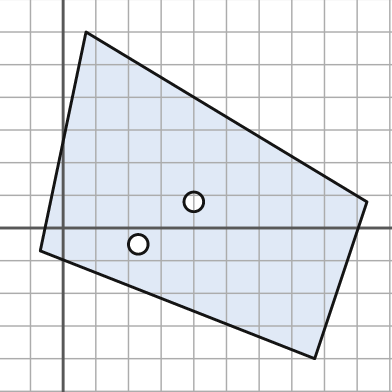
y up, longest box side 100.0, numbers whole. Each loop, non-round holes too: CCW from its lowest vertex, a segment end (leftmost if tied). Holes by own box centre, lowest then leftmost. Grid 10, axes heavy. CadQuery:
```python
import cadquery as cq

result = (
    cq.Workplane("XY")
    .moveTo(77.0, -40.0)
    .lineTo(93.0, 8.0)
    .lineTo(7.0, 60.0)
    .lineTo(-7.0, -7.0)
    .close()
    .moveTo(23.0, -5.0)
    .circle(3.0)
    .moveTo(40.0, 8.0)
    .circle(3.0)
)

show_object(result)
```